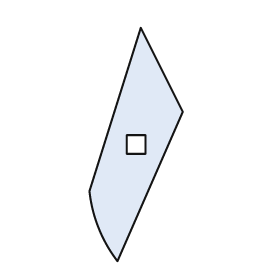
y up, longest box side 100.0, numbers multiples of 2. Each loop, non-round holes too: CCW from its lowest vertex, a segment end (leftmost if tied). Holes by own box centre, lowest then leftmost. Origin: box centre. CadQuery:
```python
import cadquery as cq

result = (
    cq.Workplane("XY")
    .moveTo(-8.0, -50.0)
    .lineTo(20.0, 14.0)
    .lineTo(2.0, 50.0)
    .lineTo(-20.0, -20.0)
    .threePointArc((-16.0, -36.0), (-8.0, -50.0))
    .close()
    .moveTo(-4.0, -4.0)
    .lineTo(4.0, -4.0)
    .lineTo(4.0, 4.0)
    .lineTo(-4.0, 4.0)
    .close()
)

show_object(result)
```